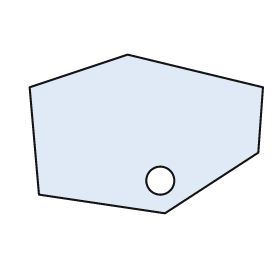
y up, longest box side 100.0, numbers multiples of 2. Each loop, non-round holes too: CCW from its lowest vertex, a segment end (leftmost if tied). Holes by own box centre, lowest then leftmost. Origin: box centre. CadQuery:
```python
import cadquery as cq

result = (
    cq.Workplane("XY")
    .moveTo(8.0, -34.0)
    .lineTo(48.0, -8.0)
    .lineTo(50.0, 20.0)
    .lineTo(-8.0, 34.0)
    .lineTo(-50.0, 20.0)
    .lineTo(-46.0, -26.0)
    .close()
    .moveTo(6.0, -20.0)
    .circle(6.0)
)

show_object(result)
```